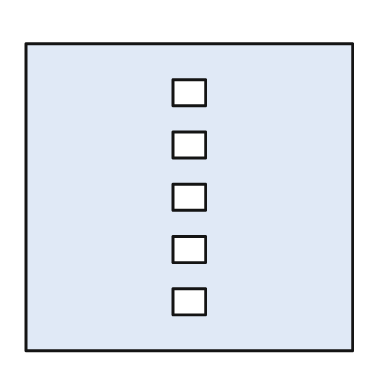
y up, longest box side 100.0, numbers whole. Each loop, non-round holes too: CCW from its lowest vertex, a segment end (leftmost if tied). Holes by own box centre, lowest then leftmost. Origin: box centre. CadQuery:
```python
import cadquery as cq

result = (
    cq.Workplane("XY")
    .moveTo(-50.0, -47.0)
    .lineTo(50.0, -47.0)
    .lineTo(50.0, 47.0)
    .lineTo(-50.0, 47.0)
    .close()
    .moveTo(-5.0, -36.0)
    .lineTo(5.0, -36.0)
    .lineTo(5.0, -28.0)
    .lineTo(-5.0, -28.0)
    .close()
    .moveTo(-5.0, -20.0)
    .lineTo(5.0, -20.0)
    .lineTo(5.0, -12.0)
    .lineTo(-5.0, -12.0)
    .close()
    .moveTo(-5.0, -4.0)
    .lineTo(5.0, -4.0)
    .lineTo(5.0, 4.0)
    .lineTo(-5.0, 4.0)
    .close()
    .moveTo(-5.0, 12.0)
    .lineTo(5.0, 12.0)
    .lineTo(5.0, 20.0)
    .lineTo(-5.0, 20.0)
    .close()
    .moveTo(-5.0, 28.0)
    .lineTo(5.0, 28.0)
    .lineTo(5.0, 36.0)
    .lineTo(-5.0, 36.0)
    .close()
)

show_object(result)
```